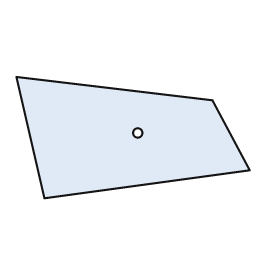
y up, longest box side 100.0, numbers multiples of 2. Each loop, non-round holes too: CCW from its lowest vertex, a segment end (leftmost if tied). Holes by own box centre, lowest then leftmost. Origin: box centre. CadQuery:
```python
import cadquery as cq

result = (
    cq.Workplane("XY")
    .moveTo(-38.0, -26.0)
    .lineTo(50.0, -14.0)
    .lineTo(34.0, 16.0)
    .lineTo(-50.0, 26.0)
    .close()
    .moveTo(2.0, 2.0)
    .circle(2.0)
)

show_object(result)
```